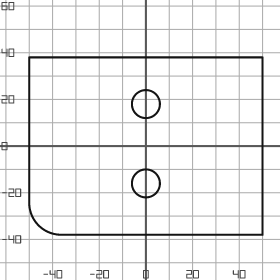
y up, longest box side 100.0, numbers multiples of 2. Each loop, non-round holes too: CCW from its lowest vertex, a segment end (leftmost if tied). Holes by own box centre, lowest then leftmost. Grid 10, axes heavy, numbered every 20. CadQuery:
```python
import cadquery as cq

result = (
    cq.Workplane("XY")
    .moveTo(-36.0, -38.0)
    .lineTo(50.0, -38.0)
    .lineTo(50.0, 38.0)
    .lineTo(-50.0, 38.0)
    .lineTo(-50.0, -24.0)
    .threePointArc((-46.0, -34.0), (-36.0, -38.0))
    .close()
    .moveTo(0.0, -16.0)
    .circle(6.0)
    .moveTo(0.0, 18.0)
    .circle(6.0)
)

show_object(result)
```